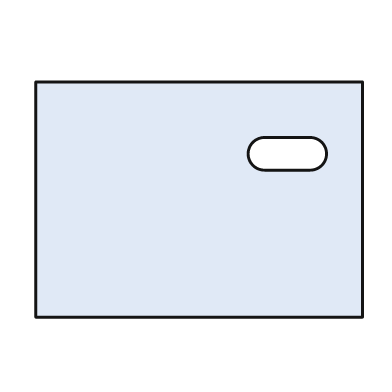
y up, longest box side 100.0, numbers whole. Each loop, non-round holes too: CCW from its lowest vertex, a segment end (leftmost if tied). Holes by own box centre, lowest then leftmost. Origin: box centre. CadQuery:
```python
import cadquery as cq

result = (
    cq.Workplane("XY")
    .moveTo(-50.0, -36.0)
    .lineTo(50.0, -36.0)
    .lineTo(50.0, 36.0)
    .lineTo(-50.0, 36.0)
    .close()
    .moveTo(20.0, 9.0)
    .lineTo(34.0, 9.0)
    .threePointArc((39.0, 14.0), (34.0, 19.0))
    .lineTo(20.0, 19.0)
    .threePointArc((15.0, 14.0), (20.0, 9.0))
    .close()
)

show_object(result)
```